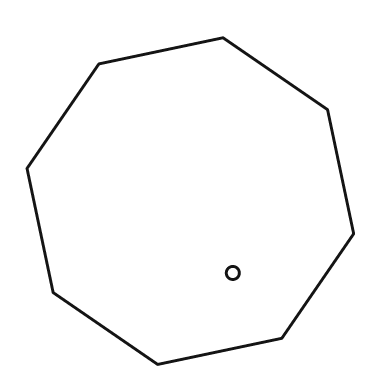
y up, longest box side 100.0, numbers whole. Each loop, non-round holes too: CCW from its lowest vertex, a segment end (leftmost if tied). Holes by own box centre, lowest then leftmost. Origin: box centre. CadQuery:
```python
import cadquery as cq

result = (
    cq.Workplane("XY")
    .moveTo(-10.0, -50.0)
    .lineTo(28.0, -42.0)
    .lineTo(50.0, -10.0)
    .lineTo(42.0, 28.0)
    .lineTo(10.0, 50.0)
    .lineTo(-28.0, 42.0)
    .lineTo(-50.0, 10.0)
    .lineTo(-42.0, -28.0)
    .close()
    .moveTo(13.0, -22.0)
    .circle(2.0)
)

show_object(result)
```